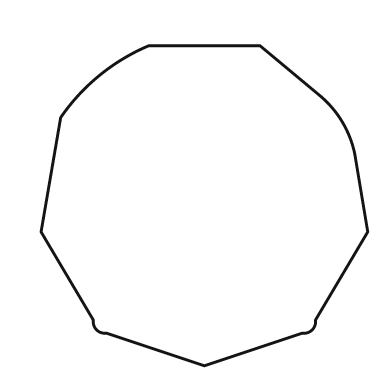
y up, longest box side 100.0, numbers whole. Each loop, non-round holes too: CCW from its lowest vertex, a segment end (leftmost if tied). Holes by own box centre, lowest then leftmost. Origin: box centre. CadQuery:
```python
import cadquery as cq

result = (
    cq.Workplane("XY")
    .moveTo(0.0, -49.0)
    .lineTo(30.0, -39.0)
    .threePointArc((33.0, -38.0), (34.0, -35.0))
    .lineTo(50.0, -8.0)
    .lineTo(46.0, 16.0)
    .threePointArc((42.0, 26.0), (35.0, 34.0))
    .lineTo(17.0, 49.0)
    .lineTo(-17.0, 49.0)
    .threePointArc((-32.0, 40.0), (-44.0, 27.0))
    .lineTo(-50.0, -8.0)
    .lineTo(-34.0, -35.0)
    .threePointArc((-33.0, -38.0), (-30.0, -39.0))
    .close()
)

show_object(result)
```